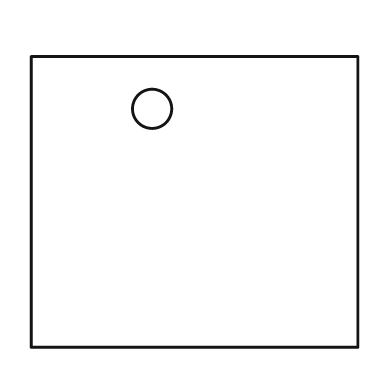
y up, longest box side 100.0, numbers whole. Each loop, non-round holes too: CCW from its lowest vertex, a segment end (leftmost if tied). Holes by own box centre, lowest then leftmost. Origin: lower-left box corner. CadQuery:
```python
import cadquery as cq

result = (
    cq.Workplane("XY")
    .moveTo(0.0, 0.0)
    .lineTo(100.0, 0.0)
    .lineTo(100.0, 89.0)
    .lineTo(0.0, 89.0)
    .close()
    .moveTo(37.0, 73.0)
    .circle(6.0)
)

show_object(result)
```